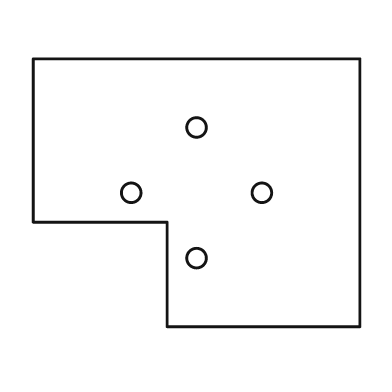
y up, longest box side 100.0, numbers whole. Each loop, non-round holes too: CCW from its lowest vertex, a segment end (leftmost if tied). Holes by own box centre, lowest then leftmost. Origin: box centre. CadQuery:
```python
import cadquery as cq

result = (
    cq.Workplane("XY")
    .moveTo(-9.0, -41.0)
    .lineTo(50.0, -41.0)
    .lineTo(50.0, 41.0)
    .lineTo(-50.0, 41.0)
    .lineTo(-50.0, -9.0)
    .lineTo(-9.0, -9.0)
    .close()
    .moveTo(0.0, -20.0)
    .circle(3.0)
    .moveTo(-20.0, 0.0)
    .circle(3.0)
    .moveTo(20.0, 0.0)
    .circle(3.0)
    .moveTo(0.0, 20.0)
    .circle(3.0)
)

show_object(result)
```